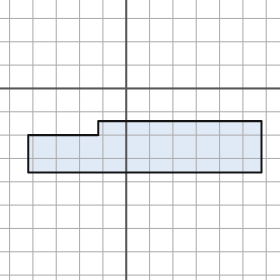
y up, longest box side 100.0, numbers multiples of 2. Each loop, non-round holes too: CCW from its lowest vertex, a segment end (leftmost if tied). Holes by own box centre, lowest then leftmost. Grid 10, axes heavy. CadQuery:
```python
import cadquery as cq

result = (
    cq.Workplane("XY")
    .moveTo(-42.0, -36.0)
    .lineTo(58.0, -36.0)
    .lineTo(58.0, -14.0)
    .lineTo(-12.0, -14.0)
    .lineTo(-12.0, -20.0)
    .lineTo(-42.0, -20.0)
    .close()
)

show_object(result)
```